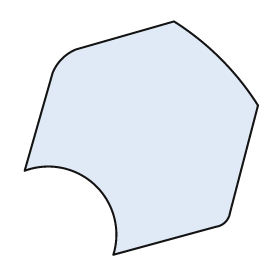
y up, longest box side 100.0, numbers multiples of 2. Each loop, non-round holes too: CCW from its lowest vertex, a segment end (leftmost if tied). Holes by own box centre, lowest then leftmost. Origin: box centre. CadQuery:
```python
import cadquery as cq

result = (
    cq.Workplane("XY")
    .moveTo(-12.0, -50.0)
    .lineTo(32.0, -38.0)
    .threePointArc((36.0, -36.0), (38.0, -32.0))
    .lineTo(50.0, 14.0)
    .threePointArc((34.0, 34.0), (14.0, 50.0))
    .lineTo(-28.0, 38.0)
    .threePointArc((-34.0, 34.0), (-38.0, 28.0))
    .lineTo(-50.0, -14.0)
    .threePointArc((-20.0, -20.0), (-12.0, -50.0))
    .close()
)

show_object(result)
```